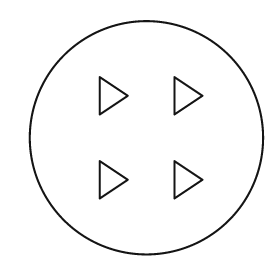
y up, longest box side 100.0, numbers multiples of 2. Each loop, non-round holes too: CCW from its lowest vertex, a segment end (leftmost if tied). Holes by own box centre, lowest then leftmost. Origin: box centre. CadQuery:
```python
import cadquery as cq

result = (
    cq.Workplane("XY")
    .moveTo(0.0, 0.0)
    .circle(50.0)
    .moveTo(-20.0, -26.0)
    .lineTo(-8.0, -18.0)
    .lineTo(-20.0, -10.0)
    .close()
    .moveTo(12.0, -26.0)
    .lineTo(24.0, -18.0)
    .lineTo(12.0, -10.0)
    .close()
    .moveTo(-20.0, 10.0)
    .lineTo(-8.0, 18.0)
    .lineTo(-20.0, 26.0)
    .close()
    .moveTo(12.0, 10.0)
    .lineTo(24.0, 18.0)
    .lineTo(12.0, 26.0)
    .close()
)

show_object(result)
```